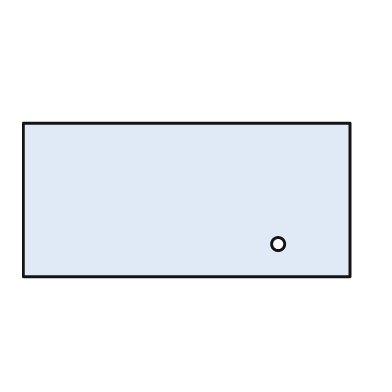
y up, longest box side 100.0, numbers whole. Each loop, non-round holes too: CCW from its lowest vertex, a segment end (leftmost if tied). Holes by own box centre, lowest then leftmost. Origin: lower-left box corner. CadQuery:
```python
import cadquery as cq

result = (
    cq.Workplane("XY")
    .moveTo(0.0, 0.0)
    .lineTo(100.0, 0.0)
    .lineTo(100.0, 47.0)
    .lineTo(0.0, 47.0)
    .close()
    .moveTo(78.0, 10.0)
    .circle(2.0)
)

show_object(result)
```